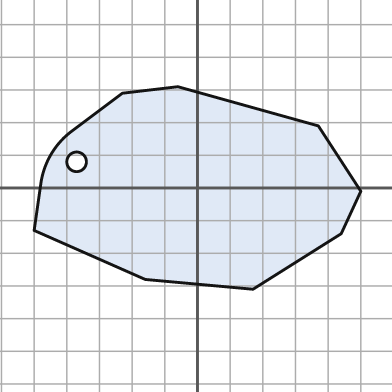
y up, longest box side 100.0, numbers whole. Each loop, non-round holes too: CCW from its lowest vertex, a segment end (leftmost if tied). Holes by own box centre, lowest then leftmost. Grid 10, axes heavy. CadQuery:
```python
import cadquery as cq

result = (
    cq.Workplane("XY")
    .moveTo(17.0, -31.0)
    .lineTo(44.0, -14.0)
    .lineTo(50.0, -1.0)
    .lineTo(37.0, 19.0)
    .lineTo(-6.0, 31.0)
    .lineTo(-23.0, 29.0)
    .lineTo(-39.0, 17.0)
    .threePointArc((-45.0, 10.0), (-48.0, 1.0))
    .lineTo(-50.0, -13.0)
    .lineTo(-16.0, -28.0)
    .close()
    .moveTo(-37.0, 8.0)
    .circle(3.0)
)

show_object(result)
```